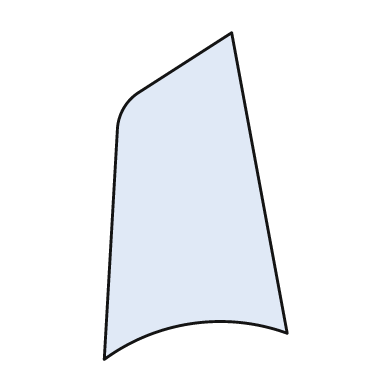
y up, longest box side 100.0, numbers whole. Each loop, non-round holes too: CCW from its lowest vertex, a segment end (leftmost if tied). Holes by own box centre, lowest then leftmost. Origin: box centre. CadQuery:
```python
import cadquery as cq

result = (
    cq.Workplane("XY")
    .moveTo(-28.0, -50.0)
    .threePointArc((-1.0, -39.0), (28.0, -42.0))
    .lineTo(11.0, 50.0)
    .lineTo(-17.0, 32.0)
    .threePointArc((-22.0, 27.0), (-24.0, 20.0))
    .close()
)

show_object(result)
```